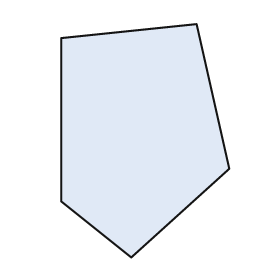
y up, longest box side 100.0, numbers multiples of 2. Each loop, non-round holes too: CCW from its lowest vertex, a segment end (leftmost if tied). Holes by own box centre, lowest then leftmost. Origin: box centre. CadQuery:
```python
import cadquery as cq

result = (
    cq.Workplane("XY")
    .moveTo(-6.0, -50.0)
    .lineTo(36.0, -12.0)
    .lineTo(22.0, 50.0)
    .lineTo(-36.0, 44.0)
    .lineTo(-36.0, -26.0)
    .close()
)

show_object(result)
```